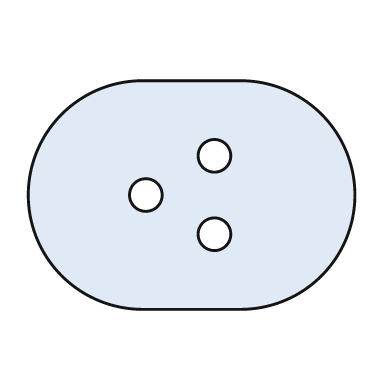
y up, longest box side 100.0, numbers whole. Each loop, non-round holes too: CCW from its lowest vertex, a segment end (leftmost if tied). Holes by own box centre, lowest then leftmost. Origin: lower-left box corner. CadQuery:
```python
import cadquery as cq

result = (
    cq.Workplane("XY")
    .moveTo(35.0, 0.0)
    .lineTo(65.0, 0.0)
    .threePointArc((100.0, 35.0), (65.0, 70.0))
    .lineTo(35.0, 70.0)
    .threePointArc((0.0, 35.0), (35.0, 0.0))
    .close()
    .moveTo(57.0, 23.0)
    .circle(5.0)
    .moveTo(36.0, 35.0)
    .circle(5.0)
    .moveTo(57.0, 47.0)
    .circle(5.0)
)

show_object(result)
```